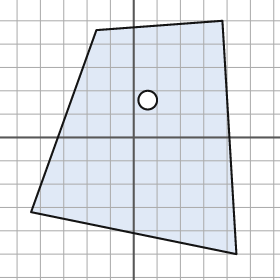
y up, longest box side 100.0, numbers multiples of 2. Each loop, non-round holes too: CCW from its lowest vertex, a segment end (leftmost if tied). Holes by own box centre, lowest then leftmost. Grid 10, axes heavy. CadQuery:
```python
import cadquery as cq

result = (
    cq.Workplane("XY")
    .moveTo(44.0, -50.0)
    .lineTo(38.0, 50.0)
    .lineTo(-16.0, 46.0)
    .lineTo(-44.0, -32.0)
    .close()
    .moveTo(6.0, 16.0)
    .circle(4.0)
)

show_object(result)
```